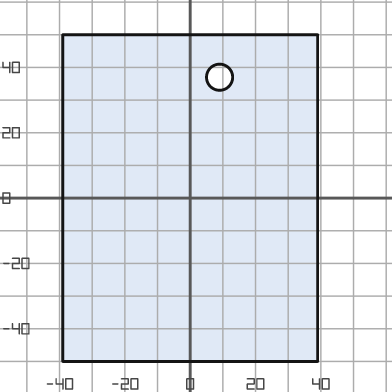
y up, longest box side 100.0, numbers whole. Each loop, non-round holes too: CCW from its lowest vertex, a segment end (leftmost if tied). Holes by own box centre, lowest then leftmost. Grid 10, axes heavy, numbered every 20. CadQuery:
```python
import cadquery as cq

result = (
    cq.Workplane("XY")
    .moveTo(-39.0, -50.0)
    .lineTo(39.0, -50.0)
    .lineTo(39.0, 50.0)
    .lineTo(-39.0, 50.0)
    .close()
    .moveTo(9.0, 37.0)
    .circle(4.0)
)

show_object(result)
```